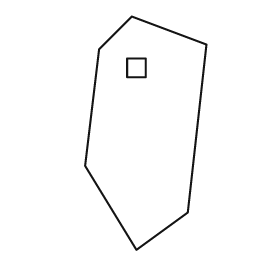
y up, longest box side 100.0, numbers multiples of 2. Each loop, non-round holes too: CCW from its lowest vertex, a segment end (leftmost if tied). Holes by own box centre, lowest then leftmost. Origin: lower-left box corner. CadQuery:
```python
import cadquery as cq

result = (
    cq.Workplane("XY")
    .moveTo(22.0, 0.0)
    .lineTo(44.0, 16.0)
    .lineTo(52.0, 88.0)
    .lineTo(20.0, 100.0)
    .lineTo(6.0, 86.0)
    .lineTo(0.0, 36.0)
    .close()
    .moveTo(18.0, 74.0)
    .lineTo(26.0, 74.0)
    .lineTo(26.0, 82.0)
    .lineTo(18.0, 82.0)
    .close()
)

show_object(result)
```